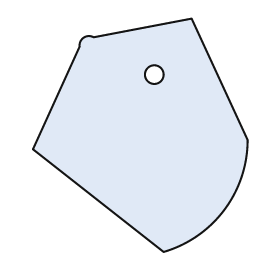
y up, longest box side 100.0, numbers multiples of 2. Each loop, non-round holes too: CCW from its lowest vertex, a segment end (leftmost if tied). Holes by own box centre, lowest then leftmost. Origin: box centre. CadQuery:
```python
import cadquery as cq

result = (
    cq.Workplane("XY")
    .moveTo(10.0, -50.0)
    .threePointArc((36.0, -32.0), (46.0, -2.0))
    .lineTo(22.0, 50.0)
    .lineTo(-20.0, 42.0)
    .threePointArc((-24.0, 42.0), (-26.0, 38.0))
    .lineTo(-46.0, -6.0)
    .close()
    .moveTo(6.0, 26.0)
    .circle(4.0)
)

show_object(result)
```